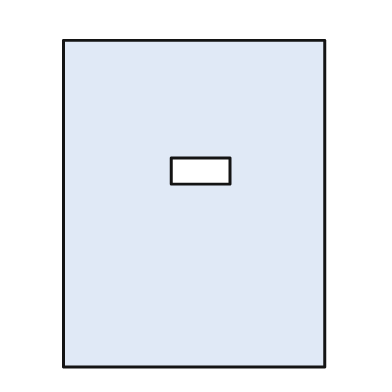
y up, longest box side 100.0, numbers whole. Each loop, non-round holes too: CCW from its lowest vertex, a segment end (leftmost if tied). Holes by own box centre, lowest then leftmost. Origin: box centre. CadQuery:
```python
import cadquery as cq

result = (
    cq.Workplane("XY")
    .moveTo(-40.0, -50.0)
    .lineTo(40.0, -50.0)
    .lineTo(40.0, 50.0)
    .lineTo(-40.0, 50.0)
    .close()
    .moveTo(-7.0, 6.0)
    .lineTo(11.0, 6.0)
    .lineTo(11.0, 14.0)
    .lineTo(-7.0, 14.0)
    .close()
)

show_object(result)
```